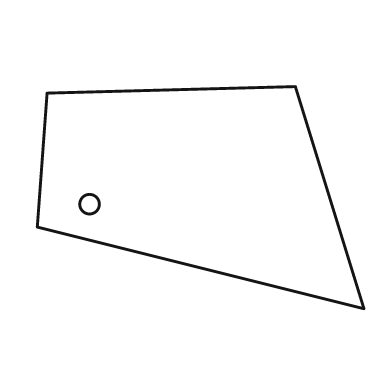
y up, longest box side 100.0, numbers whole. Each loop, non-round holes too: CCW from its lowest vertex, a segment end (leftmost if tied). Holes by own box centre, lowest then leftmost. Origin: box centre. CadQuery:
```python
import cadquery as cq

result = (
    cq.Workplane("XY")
    .moveTo(50.0, -34.0)
    .lineTo(29.0, 34.0)
    .lineTo(-47.0, 32.0)
    .lineTo(-50.0, -9.0)
    .close()
    .moveTo(-34.0, -2.0)
    .circle(3.0)
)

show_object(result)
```